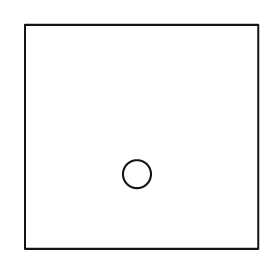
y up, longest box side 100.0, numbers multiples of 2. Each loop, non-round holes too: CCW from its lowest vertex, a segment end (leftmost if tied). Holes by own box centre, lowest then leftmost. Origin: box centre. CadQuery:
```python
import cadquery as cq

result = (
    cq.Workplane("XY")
    .moveTo(-50.0, -48.0)
    .lineTo(50.0, -48.0)
    .lineTo(50.0, 48.0)
    .lineTo(-50.0, 48.0)
    .close()
    .moveTo(-2.0, -16.0)
    .circle(6.0)
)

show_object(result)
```